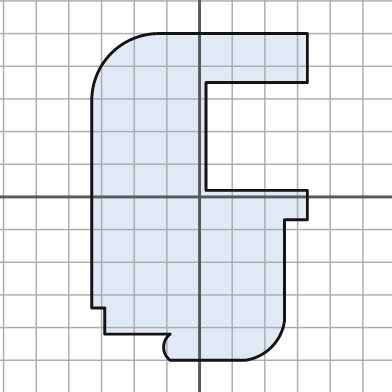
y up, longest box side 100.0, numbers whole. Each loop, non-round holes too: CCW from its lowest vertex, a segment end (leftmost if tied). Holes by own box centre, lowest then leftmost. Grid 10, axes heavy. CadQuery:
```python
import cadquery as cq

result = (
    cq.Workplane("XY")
    .moveTo(-9.0, -50.0)
    .lineTo(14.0, -50.0)
    .threePointArc((22.0, -46.0), (26.0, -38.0))
    .lineTo(26.0, -7.0)
    .lineTo(33.0, -7.0)
    .lineTo(33.0, 2.0)
    .lineTo(2.0, 2.0)
    .lineTo(2.0, 35.0)
    .lineTo(33.0, 35.0)
    .lineTo(33.0, 50.0)
    .lineTo(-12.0, 50.0)
    .threePointArc((-27.0, 44.0), (-33.0, 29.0))
    .lineTo(-33.0, -34.0)
    .lineTo(-29.0, -34.0)
    .lineTo(-29.0, -42.0)
    .lineTo(-9.0, -42.0)
    .threePointArc((-11.0, -46.0), (-9.0, -50.0))
    .close()
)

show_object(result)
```